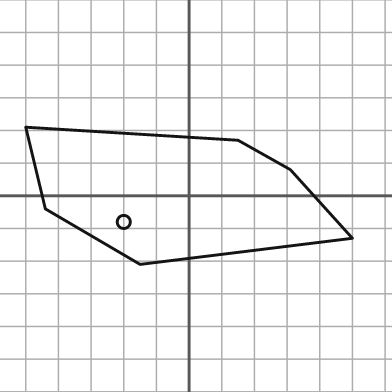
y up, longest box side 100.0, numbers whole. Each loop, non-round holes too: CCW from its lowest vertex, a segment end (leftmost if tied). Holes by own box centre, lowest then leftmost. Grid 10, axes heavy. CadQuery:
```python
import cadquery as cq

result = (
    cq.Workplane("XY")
    .moveTo(-15.0, -21.0)
    .lineTo(50.0, -13.0)
    .lineTo(31.0, 8.0)
    .lineTo(15.0, 17.0)
    .lineTo(-50.0, 21.0)
    .lineTo(-44.0, -4.0)
    .close()
    .moveTo(-20.0, -8.0)
    .circle(2.0)
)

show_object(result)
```